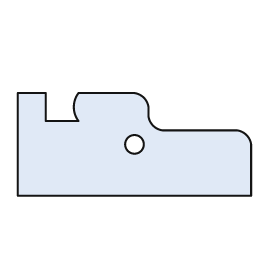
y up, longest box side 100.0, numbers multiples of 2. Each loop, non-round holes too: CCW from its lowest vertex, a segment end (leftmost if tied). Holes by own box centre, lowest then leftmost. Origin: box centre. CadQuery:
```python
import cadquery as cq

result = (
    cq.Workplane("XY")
    .moveTo(-50.0, -22.0)
    .lineTo(50.0, -22.0)
    .lineTo(50.0, 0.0)
    .threePointArc((48.0, 4.0), (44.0, 6.0))
    .lineTo(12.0, 6.0)
    .threePointArc((8.0, 8.0), (6.0, 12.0))
    .lineTo(6.0, 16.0)
    .threePointArc((4.0, 20.0), (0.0, 22.0))
    .lineTo(-24.0, 22.0)
    .threePointArc((-26.0, 16.0), (-24.0, 10.0))
    .lineTo(-38.0, 10.0)
    .lineTo(-38.0, 22.0)
    .lineTo(-50.0, 22.0)
    .close()
    .moveTo(0.0, 0.0)
    .circle(4.0)
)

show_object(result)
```